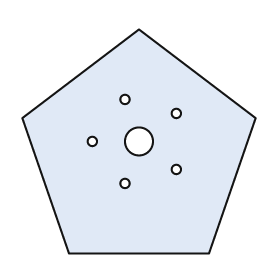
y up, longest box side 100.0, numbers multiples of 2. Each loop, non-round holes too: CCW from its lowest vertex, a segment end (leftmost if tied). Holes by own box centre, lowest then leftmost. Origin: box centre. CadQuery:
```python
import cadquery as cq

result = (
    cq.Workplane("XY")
    .moveTo(-30.0, -48.0)
    .lineTo(30.0, -48.0)
    .lineTo(50.0, 10.0)
    .lineTo(0.0, 48.0)
    .lineTo(-50.0, 10.0)
    .close()
    .moveTo(-6.0, -18.0)
    .circle(2.0)
    .moveTo(16.0, -12.0)
    .circle(2.0)
    .moveTo(-20.0, 0.0)
    .circle(2.0)
    .moveTo(0.0, 0.0)
    .circle(6.0)
    .moveTo(16.0, 12.0)
    .circle(2.0)
    .moveTo(-6.0, 18.0)
    .circle(2.0)
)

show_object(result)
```